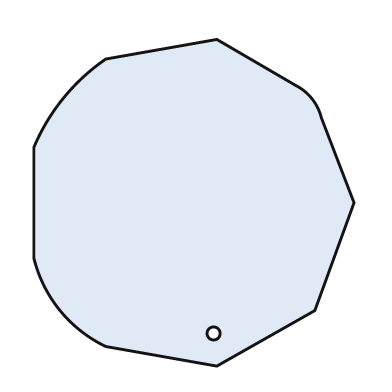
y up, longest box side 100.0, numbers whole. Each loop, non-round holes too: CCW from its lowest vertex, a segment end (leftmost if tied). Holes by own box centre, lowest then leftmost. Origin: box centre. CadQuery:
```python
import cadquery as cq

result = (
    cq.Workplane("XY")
    .moveTo(7.0, -50.0)
    .lineTo(37.0, -33.0)
    .lineTo(49.0, 0.0)
    .lineTo(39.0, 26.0)
    .threePointArc((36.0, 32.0), (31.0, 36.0))
    .lineTo(7.0, 50.0)
    .lineTo(-27.0, 44.0)
    .threePointArc((-40.0, 32.0), (-49.0, 17.0))
    .lineTo(-49.0, -17.0)
    .threePointArc((-41.0, -33.0), (-27.0, -44.0))
    .close()
    .moveTo(6.0, -40.0)
    .circle(2.0)
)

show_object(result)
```